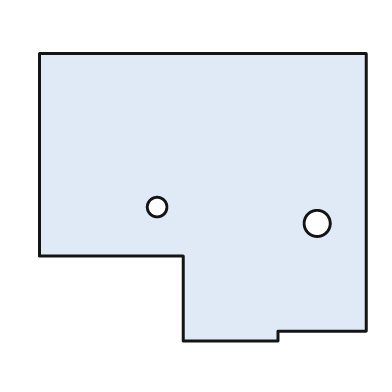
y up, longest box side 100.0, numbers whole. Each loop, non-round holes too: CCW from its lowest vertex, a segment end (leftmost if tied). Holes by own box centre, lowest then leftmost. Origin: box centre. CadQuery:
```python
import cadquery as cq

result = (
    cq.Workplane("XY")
    .moveTo(-6.0, -44.0)
    .lineTo(23.0, -44.0)
    .lineTo(23.0, -41.0)
    .lineTo(50.0, -41.0)
    .lineTo(50.0, 44.0)
    .lineTo(-50.0, 44.0)
    .lineTo(-50.0, -18.0)
    .lineTo(-6.0, -18.0)
    .close()
    .moveTo(35.0, -8.0)
    .circle(4.0)
    .moveTo(-14.0, -3.0)
    .circle(3.0)
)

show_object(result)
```